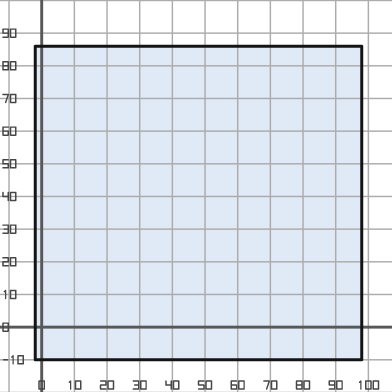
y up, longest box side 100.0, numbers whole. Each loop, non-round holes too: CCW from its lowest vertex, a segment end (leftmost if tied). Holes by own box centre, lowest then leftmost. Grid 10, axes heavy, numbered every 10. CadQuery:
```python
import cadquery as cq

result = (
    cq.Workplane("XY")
    .moveTo(-2.0, -10.0)
    .lineTo(98.0, -10.0)
    .lineTo(98.0, 86.0)
    .lineTo(-2.0, 86.0)
    .close()
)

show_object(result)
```